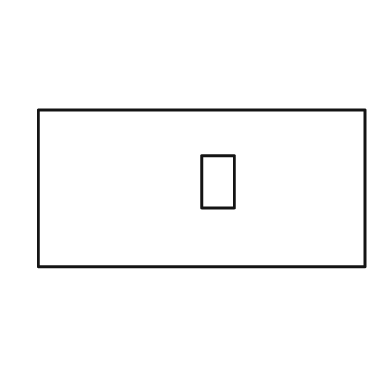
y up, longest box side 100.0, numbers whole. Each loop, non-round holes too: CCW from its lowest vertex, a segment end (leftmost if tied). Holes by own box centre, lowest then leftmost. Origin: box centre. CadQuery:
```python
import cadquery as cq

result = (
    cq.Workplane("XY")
    .moveTo(-50.0, -24.0)
    .lineTo(50.0, -24.0)
    .lineTo(50.0, 24.0)
    .lineTo(-50.0, 24.0)
    .close()
    .moveTo(0.0, -6.0)
    .lineTo(10.0, -6.0)
    .lineTo(10.0, 10.0)
    .lineTo(0.0, 10.0)
    .close()
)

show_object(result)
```